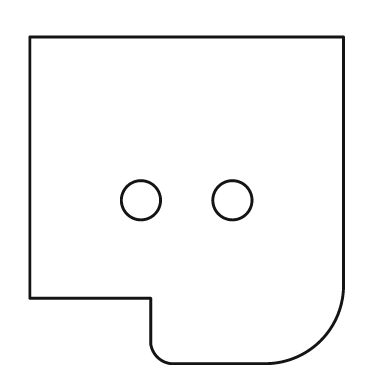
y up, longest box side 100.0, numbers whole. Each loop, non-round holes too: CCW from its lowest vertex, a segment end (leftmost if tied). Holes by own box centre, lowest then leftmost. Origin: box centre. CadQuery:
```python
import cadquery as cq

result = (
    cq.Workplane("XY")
    .moveTo(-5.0, -50.0)
    .lineTo(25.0, -50.0)
    .threePointArc((41.0, -43.0), (48.0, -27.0))
    .lineTo(48.0, 50.0)
    .lineTo(-48.0, 50.0)
    .lineTo(-48.0, -30.0)
    .lineTo(-11.0, -30.0)
    .lineTo(-11.0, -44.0)
    .threePointArc((-9.0, -48.0), (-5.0, -50.0))
    .close()
    .moveTo(-14.0, 0.0)
    .circle(6.0)
    .moveTo(14.0, 0.0)
    .circle(6.0)
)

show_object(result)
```